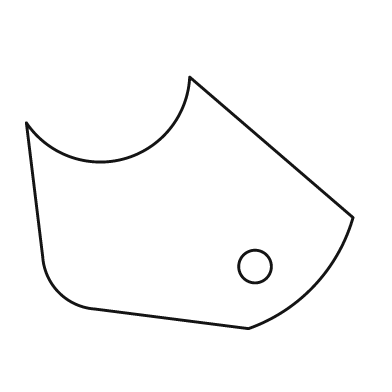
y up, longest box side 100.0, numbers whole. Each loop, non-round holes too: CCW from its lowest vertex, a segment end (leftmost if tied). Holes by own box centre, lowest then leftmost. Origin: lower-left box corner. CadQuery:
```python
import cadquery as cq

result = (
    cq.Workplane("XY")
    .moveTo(68.0, 0.0)
    .threePointArc((88.0, 13.0), (100.0, 34.0))
    .lineTo(50.0, 77.0)
    .threePointArc((30.0, 52.0), (0.0, 63.0))
    .lineTo(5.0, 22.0)
    .threePointArc((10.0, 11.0), (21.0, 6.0))
    .close()
    .moveTo(70.0, 19.0)
    .circle(5.0)
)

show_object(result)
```